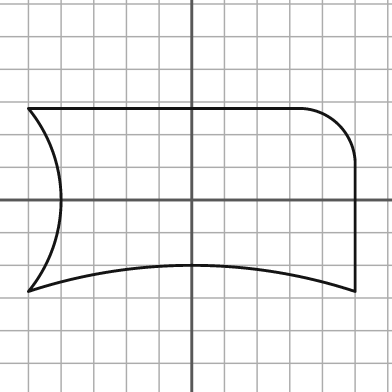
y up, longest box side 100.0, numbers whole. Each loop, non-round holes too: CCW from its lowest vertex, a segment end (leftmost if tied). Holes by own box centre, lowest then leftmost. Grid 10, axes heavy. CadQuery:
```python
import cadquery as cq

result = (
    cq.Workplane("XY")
    .moveTo(-50.0, -28.0)
    .threePointArc((0.0, -20.0), (50.0, -28.0))
    .lineTo(50.0, 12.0)
    .threePointArc((45.0, 23.0), (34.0, 28.0))
    .lineTo(-50.0, 28.0)
    .threePointArc((-40.0, 0.0), (-50.0, -28.0))
    .close()
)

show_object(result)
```